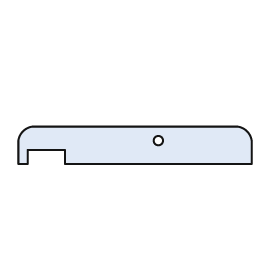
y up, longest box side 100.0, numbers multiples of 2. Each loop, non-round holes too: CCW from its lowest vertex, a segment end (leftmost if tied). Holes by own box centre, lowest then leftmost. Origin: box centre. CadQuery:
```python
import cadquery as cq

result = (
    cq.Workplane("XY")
    .moveTo(-50.0, -8.0)
    .lineTo(-46.0, -8.0)
    .lineTo(-46.0, -2.0)
    .lineTo(-30.0, -2.0)
    .lineTo(-30.0, -8.0)
    .lineTo(50.0, -8.0)
    .lineTo(50.0, 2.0)
    .threePointArc((48.0, 6.0), (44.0, 8.0))
    .lineTo(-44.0, 8.0)
    .threePointArc((-48.0, 6.0), (-50.0, 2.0))
    .close()
    .moveTo(10.0, 2.0)
    .circle(2.0)
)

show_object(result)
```